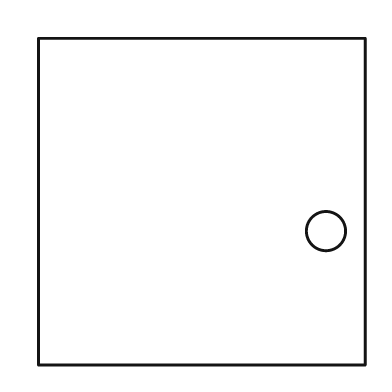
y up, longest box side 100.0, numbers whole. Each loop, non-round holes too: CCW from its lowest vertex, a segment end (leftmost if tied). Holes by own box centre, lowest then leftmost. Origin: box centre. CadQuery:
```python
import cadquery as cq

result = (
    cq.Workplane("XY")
    .moveTo(-50.0, -50.0)
    .lineTo(50.0, -50.0)
    .lineTo(50.0, 50.0)
    .lineTo(-50.0, 50.0)
    .close()
    .moveTo(38.0, -9.0)
    .circle(6.0)
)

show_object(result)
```